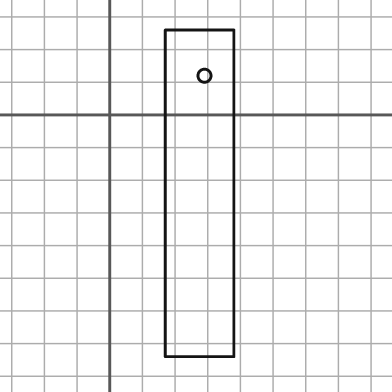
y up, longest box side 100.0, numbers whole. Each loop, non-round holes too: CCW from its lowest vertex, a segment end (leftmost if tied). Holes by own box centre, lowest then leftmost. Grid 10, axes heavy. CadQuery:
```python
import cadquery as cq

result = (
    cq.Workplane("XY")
    .moveTo(17.0, -74.0)
    .lineTo(38.0, -74.0)
    .lineTo(38.0, 26.0)
    .lineTo(17.0, 26.0)
    .close()
    .moveTo(29.0, 12.0)
    .circle(2.0)
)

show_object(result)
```